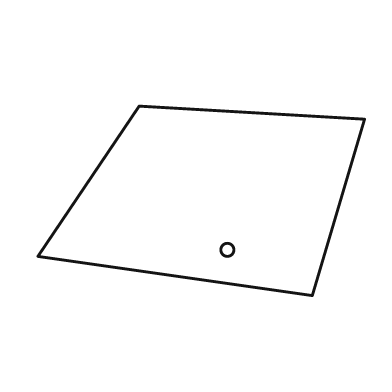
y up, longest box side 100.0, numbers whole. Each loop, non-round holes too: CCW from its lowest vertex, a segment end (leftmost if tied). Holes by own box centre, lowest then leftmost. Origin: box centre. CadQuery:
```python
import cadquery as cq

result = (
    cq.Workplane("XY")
    .moveTo(34.0, -29.0)
    .lineTo(50.0, 25.0)
    .lineTo(-19.0, 29.0)
    .lineTo(-50.0, -17.0)
    .close()
    .moveTo(8.0, -15.0)
    .circle(2.0)
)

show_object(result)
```